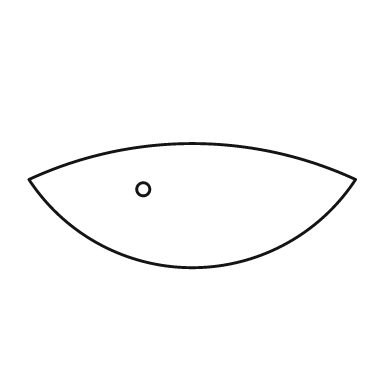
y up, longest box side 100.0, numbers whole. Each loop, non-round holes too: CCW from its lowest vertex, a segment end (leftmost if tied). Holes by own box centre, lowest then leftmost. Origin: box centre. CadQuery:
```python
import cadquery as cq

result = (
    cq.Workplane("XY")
    .moveTo(-50.0, 8.0)
    .threePointArc((0.0, -19.0), (50.0, 8.0))
    .threePointArc((0.0, 19.0), (-50.0, 8.0))
    .close()
    .moveTo(-15.0, 5.0)
    .circle(2.0)
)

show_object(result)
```